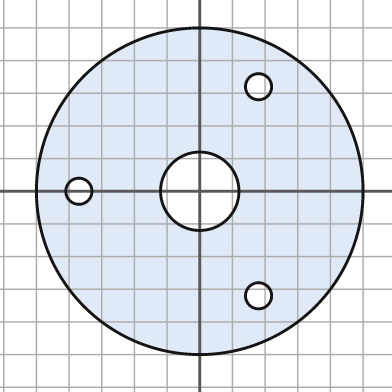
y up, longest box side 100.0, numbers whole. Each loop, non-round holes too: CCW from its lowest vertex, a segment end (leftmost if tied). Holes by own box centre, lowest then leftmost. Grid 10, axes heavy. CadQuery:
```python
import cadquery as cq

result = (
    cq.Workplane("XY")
    .moveTo(0.0, 0.0)
    .circle(50.0)
    .moveTo(18.0, -32.0)
    .circle(4.0)
    .moveTo(-37.0, 0.0)
    .circle(4.0)
    .moveTo(0.0, 0.0)
    .circle(12.0)
    .moveTo(18.0, 32.0)
    .circle(4.0)
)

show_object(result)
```